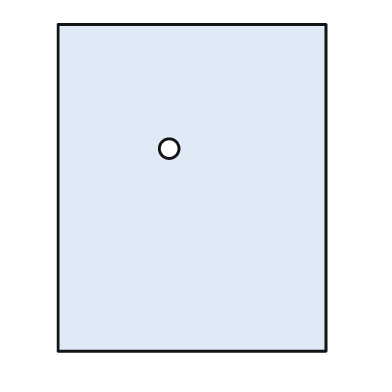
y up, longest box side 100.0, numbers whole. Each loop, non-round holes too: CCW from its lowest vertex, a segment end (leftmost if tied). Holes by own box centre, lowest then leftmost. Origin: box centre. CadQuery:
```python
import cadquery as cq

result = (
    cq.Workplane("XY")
    .moveTo(-41.0, -50.0)
    .lineTo(41.0, -50.0)
    .lineTo(41.0, 50.0)
    .lineTo(-41.0, 50.0)
    .close()
    .moveTo(-7.0, 12.0)
    .circle(3.0)
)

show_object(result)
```